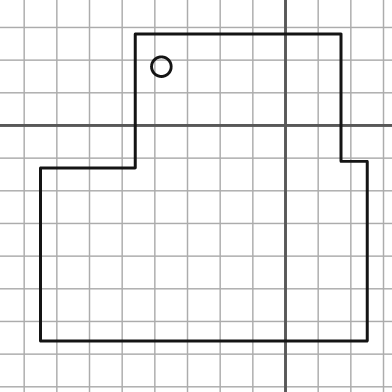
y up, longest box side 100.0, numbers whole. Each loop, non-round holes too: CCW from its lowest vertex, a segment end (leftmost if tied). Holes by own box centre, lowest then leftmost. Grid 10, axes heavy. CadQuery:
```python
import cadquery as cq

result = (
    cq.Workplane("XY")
    .moveTo(-75.0, -66.0)
    .lineTo(25.0, -66.0)
    .lineTo(25.0, -11.0)
    .lineTo(17.0, -11.0)
    .lineTo(17.0, 28.0)
    .lineTo(-46.0, 28.0)
    .lineTo(-46.0, -13.0)
    .lineTo(-75.0, -13.0)
    .close()
    .moveTo(-38.0, 18.0)
    .circle(3.0)
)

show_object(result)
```